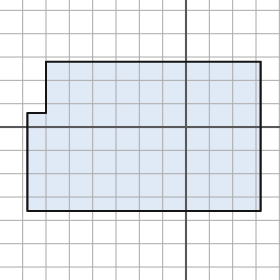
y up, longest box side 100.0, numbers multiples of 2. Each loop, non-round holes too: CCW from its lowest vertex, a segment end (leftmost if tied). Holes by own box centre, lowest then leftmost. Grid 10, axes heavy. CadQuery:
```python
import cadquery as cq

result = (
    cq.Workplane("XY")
    .moveTo(-68.0, -36.0)
    .lineTo(32.0, -36.0)
    .lineTo(32.0, 28.0)
    .lineTo(-60.0, 28.0)
    .lineTo(-60.0, 6.0)
    .lineTo(-68.0, 6.0)
    .close()
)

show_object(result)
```